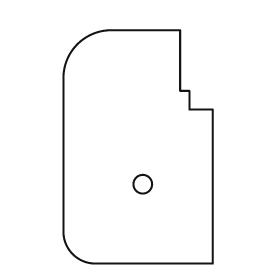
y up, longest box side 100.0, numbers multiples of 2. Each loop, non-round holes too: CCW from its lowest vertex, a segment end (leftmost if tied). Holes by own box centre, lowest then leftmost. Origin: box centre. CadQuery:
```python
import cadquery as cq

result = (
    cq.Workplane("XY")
    .moveTo(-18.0, -50.0)
    .lineTo(32.0, -50.0)
    .lineTo(32.0, 16.0)
    .lineTo(22.0, 16.0)
    .lineTo(22.0, 24.0)
    .lineTo(18.0, 24.0)
    .lineTo(18.0, 50.0)
    .lineTo(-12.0, 50.0)
    .threePointArc((-26.0, 44.0), (-32.0, 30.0))
    .lineTo(-32.0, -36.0)
    .threePointArc((-28.0, -46.0), (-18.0, -50.0))
    .close()
    .moveTo(2.0, -16.0)
    .circle(4.0)
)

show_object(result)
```